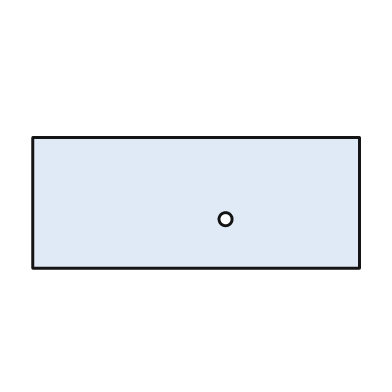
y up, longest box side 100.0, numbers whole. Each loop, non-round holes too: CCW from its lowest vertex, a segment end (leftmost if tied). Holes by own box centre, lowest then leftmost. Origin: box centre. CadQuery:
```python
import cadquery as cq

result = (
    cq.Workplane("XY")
    .moveTo(-50.0, -20.0)
    .lineTo(50.0, -20.0)
    .lineTo(50.0, 20.0)
    .lineTo(-50.0, 20.0)
    .close()
    .moveTo(9.0, -5.0)
    .circle(2.0)
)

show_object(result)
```